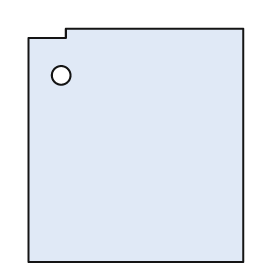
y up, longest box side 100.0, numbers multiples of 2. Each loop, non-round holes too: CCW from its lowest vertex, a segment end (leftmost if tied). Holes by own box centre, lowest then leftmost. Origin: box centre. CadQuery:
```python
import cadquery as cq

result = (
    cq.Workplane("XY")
    .moveTo(-46.0, -50.0)
    .lineTo(46.0, -50.0)
    .lineTo(46.0, 50.0)
    .lineTo(-30.0, 50.0)
    .lineTo(-30.0, 46.0)
    .lineTo(-46.0, 46.0)
    .close()
    .moveTo(-32.0, 30.0)
    .circle(4.0)
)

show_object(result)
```